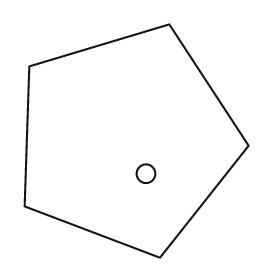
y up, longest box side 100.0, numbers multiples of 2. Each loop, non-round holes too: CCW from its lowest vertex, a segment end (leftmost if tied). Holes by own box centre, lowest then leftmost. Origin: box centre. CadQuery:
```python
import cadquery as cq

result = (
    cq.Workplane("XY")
    .moveTo(10.0, -50.0)
    .lineTo(48.0, -2.0)
    .lineTo(14.0, 50.0)
    .lineTo(-46.0, 32.0)
    .lineTo(-48.0, -28.0)
    .close()
    .moveTo(4.0, -14.0)
    .circle(4.0)
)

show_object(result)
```